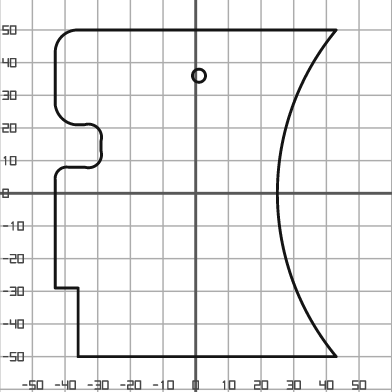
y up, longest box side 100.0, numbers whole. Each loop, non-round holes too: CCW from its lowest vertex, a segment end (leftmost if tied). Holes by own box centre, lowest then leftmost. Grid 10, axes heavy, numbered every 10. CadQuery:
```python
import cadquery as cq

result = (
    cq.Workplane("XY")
    .moveTo(-36.0, -50.0)
    .lineTo(43.0, -50.0)
    .threePointArc((25.0, 0.0), (43.0, 50.0))
    .lineTo(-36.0, 50.0)
    .threePointArc((-41.0, 48.0), (-43.0, 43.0))
    .lineTo(-43.0, 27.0)
    .threePointArc((-41.0, 23.0), (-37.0, 21.0))
    .lineTo(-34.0, 21.0)
    .threePointArc((-30.0, 20.0), (-29.0, 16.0))
    .lineTo(-29.0, 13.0)
    .threePointArc((-30.0, 9.0), (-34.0, 8.0))
    .lineTo(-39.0, 8.0)
    .threePointArc((-42.0, 7.0), (-43.0, 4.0))
    .lineTo(-43.0, -29.0)
    .lineTo(-36.0, -29.0)
    .close()
    .moveTo(1.0, 36.0)
    .circle(2.0)
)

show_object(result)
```